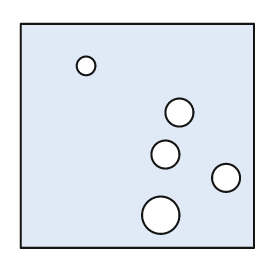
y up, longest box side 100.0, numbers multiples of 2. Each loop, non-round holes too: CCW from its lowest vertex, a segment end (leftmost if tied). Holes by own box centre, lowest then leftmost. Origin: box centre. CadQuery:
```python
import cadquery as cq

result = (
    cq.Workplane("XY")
    .moveTo(-50.0, -48.0)
    .lineTo(50.0, -48.0)
    .lineTo(50.0, 48.0)
    .lineTo(-50.0, 48.0)
    .close()
    .moveTo(10.0, -34.0)
    .circle(8.0)
    .moveTo(38.0, -18.0)
    .circle(6.0)
    .moveTo(12.0, -8.0)
    .circle(6.0)
    .moveTo(18.0, 10.0)
    .circle(6.0)
    .moveTo(-22.0, 30.0)
    .circle(4.0)
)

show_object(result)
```